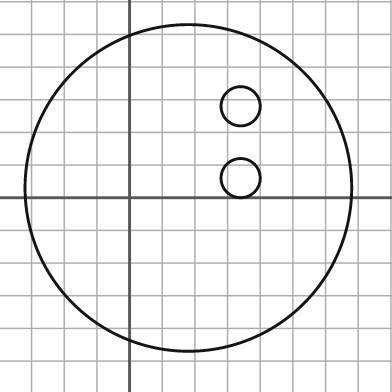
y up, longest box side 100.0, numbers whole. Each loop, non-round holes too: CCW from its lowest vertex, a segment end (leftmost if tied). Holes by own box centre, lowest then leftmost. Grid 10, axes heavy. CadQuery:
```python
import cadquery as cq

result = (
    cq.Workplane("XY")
    .moveTo(18.0, 3.0)
    .circle(50.0)
    .moveTo(34.0, 6.0)
    .circle(6.0)
    .moveTo(34.0, 28.0)
    .circle(6.0)
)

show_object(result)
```